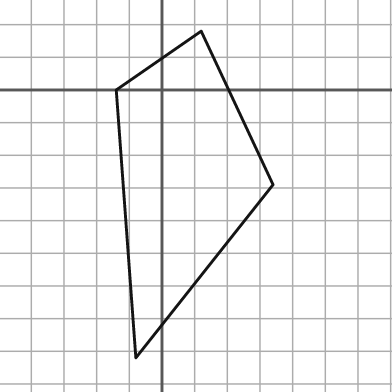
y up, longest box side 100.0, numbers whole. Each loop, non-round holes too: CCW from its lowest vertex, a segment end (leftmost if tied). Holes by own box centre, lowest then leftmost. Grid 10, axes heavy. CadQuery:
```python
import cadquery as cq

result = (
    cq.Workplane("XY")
    .moveTo(-8.0, -82.0)
    .lineTo(34.0, -29.0)
    .lineTo(12.0, 18.0)
    .lineTo(-14.0, 0.0)
    .close()
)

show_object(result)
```